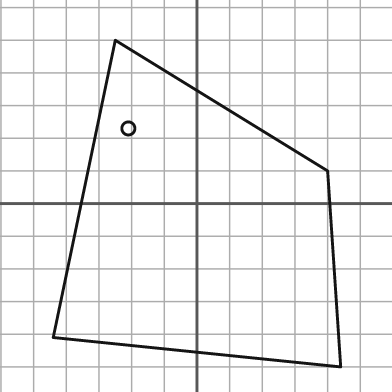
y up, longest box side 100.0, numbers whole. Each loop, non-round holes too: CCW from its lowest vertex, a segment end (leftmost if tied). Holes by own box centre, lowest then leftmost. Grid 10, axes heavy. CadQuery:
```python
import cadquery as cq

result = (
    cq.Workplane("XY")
    .moveTo(44.0, -50.0)
    .lineTo(40.0, 10.0)
    .lineTo(-25.0, 50.0)
    .lineTo(-44.0, -41.0)
    .close()
    .moveTo(-21.0, 23.0)
    .circle(2.0)
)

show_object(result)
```